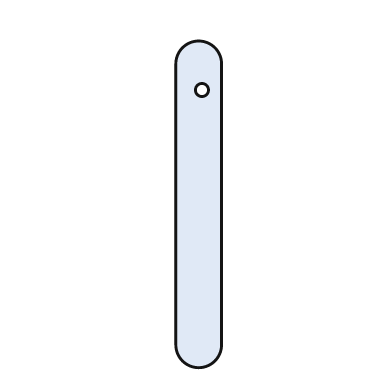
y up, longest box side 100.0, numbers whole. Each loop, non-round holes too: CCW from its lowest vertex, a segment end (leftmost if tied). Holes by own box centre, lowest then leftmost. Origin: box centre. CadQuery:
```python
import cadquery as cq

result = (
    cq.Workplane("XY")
    .moveTo(-7.0, -43.0)
    .threePointArc((0.0, -50.0), (7.0, -43.0))
    .lineTo(7.0, 43.0)
    .threePointArc((0.0, 50.0), (-7.0, 43.0))
    .close()
    .moveTo(1.0, 35.0)
    .circle(2.0)
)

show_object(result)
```